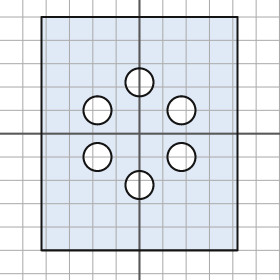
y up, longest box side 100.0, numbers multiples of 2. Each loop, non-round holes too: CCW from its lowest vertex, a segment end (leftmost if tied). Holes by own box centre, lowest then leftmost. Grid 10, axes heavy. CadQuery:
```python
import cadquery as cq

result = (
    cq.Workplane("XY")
    .moveTo(-42.0, -50.0)
    .lineTo(42.0, -50.0)
    .lineTo(42.0, 50.0)
    .lineTo(-42.0, 50.0)
    .close()
    .moveTo(0.0, -22.0)
    .circle(6.0)
    .moveTo(-18.0, -10.0)
    .circle(6.0)
    .moveTo(18.0, -10.0)
    .circle(6.0)
    .moveTo(-18.0, 10.0)
    .circle(6.0)
    .moveTo(18.0, 10.0)
    .circle(6.0)
    .moveTo(0.0, 22.0)
    .circle(6.0)
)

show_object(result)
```